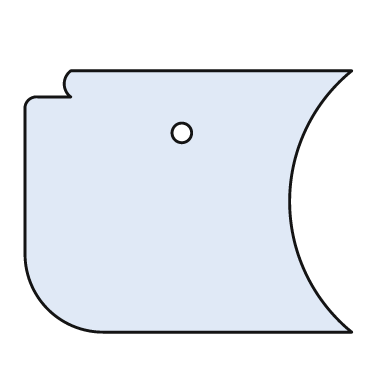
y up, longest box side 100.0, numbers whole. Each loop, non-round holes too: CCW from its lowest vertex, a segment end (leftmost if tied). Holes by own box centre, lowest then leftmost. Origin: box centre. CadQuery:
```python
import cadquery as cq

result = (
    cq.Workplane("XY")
    .moveTo(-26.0, -40.0)
    .lineTo(50.0, -40.0)
    .threePointArc((31.0, 0.0), (50.0, 40.0))
    .lineTo(-36.0, 40.0)
    .threePointArc((-38.0, 36.0), (-36.0, 32.0))
    .lineTo(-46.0, 32.0)
    .threePointArc((-49.0, 31.0), (-50.0, 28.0))
    .lineTo(-50.0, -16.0)
    .threePointArc((-43.0, -33.0), (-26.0, -40.0))
    .close()
    .moveTo(-2.0, 21.0)
    .circle(3.0)
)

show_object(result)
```